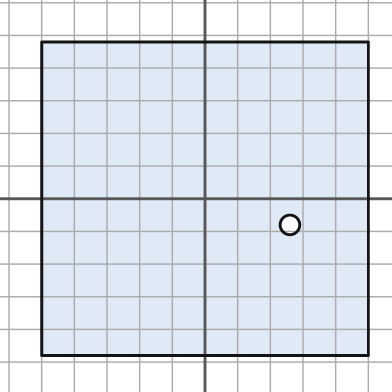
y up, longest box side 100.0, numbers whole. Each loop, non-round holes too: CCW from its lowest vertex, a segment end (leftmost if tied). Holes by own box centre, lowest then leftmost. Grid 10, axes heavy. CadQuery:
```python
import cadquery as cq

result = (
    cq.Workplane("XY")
    .moveTo(-50.0, -48.0)
    .lineTo(50.0, -48.0)
    .lineTo(50.0, 48.0)
    .lineTo(-50.0, 48.0)
    .close()
    .moveTo(26.0, -8.0)
    .circle(3.0)
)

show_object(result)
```